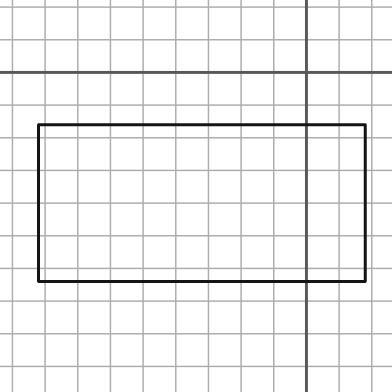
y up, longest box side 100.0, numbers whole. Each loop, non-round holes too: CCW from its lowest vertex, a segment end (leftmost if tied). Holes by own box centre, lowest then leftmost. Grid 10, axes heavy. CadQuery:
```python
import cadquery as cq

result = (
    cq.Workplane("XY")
    .moveTo(-82.0, -64.0)
    .lineTo(18.0, -64.0)
    .lineTo(18.0, -16.0)
    .lineTo(-82.0, -16.0)
    .close()
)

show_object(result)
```